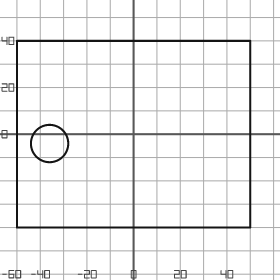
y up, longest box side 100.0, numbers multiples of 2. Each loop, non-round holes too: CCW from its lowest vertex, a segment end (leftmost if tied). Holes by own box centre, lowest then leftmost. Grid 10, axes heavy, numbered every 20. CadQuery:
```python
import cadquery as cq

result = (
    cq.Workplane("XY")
    .moveTo(-50.0, -40.0)
    .lineTo(50.0, -40.0)
    .lineTo(50.0, 40.0)
    .lineTo(-50.0, 40.0)
    .close()
    .moveTo(-36.0, -4.0)
    .circle(8.0)
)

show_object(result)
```